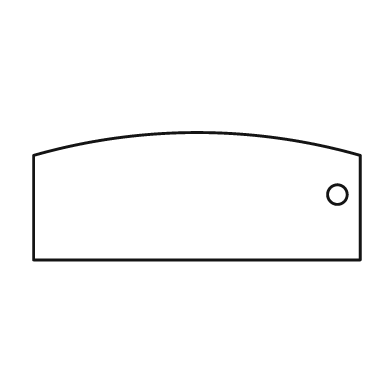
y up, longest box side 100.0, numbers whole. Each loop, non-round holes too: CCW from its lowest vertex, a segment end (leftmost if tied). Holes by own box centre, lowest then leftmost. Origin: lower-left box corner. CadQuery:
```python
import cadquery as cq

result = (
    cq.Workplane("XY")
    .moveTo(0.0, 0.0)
    .lineTo(100.0, 0.0)
    .lineTo(100.0, 32.0)
    .threePointArc((50.0, 39.0), (0.0, 32.0))
    .close()
    .moveTo(93.0, 20.0)
    .circle(3.0)
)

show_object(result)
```